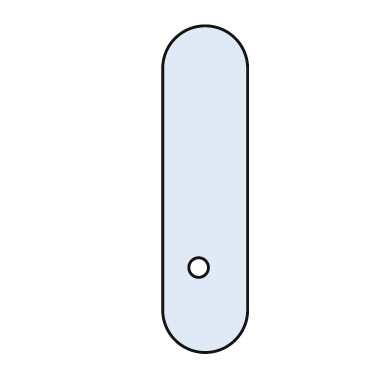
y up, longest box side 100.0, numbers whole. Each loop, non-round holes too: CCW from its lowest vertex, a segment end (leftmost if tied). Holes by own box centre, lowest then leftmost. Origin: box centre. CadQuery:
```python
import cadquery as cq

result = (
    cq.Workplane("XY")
    .moveTo(-13.0, -37.0)
    .threePointArc((0.0, -50.0), (13.0, -37.0))
    .lineTo(13.0, 37.0)
    .threePointArc((0.0, 50.0), (-13.0, 37.0))
    .close()
    .moveTo(-2.0, -24.0)
    .circle(3.0)
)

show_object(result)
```